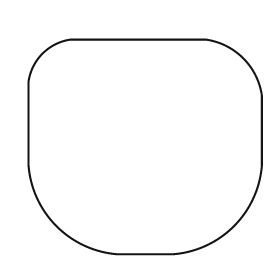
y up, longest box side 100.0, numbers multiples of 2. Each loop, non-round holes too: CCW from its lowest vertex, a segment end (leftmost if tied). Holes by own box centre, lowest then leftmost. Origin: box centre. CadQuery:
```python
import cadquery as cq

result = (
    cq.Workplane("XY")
    .moveTo(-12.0, -46.0)
    .lineTo(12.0, -46.0)
    .threePointArc((38.0, -34.0), (50.0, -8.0))
    .lineTo(50.0, 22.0)
    .threePointArc((42.0, 38.0), (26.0, 46.0))
    .lineTo(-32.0, 46.0)
    .threePointArc((-44.0, 40.0), (-50.0, 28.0))
    .lineTo(-50.0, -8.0)
    .threePointArc((-38.0, -34.0), (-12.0, -46.0))
    .close()
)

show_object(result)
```